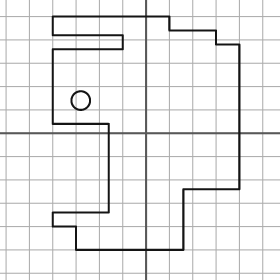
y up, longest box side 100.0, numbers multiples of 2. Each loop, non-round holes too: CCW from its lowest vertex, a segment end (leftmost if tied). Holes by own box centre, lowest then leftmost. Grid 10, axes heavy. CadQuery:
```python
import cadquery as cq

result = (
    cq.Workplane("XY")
    .moveTo(-30.0, -50.0)
    .lineTo(16.0, -50.0)
    .lineTo(16.0, -24.0)
    .lineTo(40.0, -24.0)
    .lineTo(40.0, 38.0)
    .lineTo(30.0, 38.0)
    .lineTo(30.0, 44.0)
    .lineTo(10.0, 44.0)
    .lineTo(10.0, 50.0)
    .lineTo(-40.0, 50.0)
    .lineTo(-40.0, 42.0)
    .lineTo(-10.0, 42.0)
    .lineTo(-10.0, 36.0)
    .lineTo(-40.0, 36.0)
    .lineTo(-40.0, 4.0)
    .lineTo(-16.0, 4.0)
    .lineTo(-16.0, -34.0)
    .lineTo(-40.0, -34.0)
    .lineTo(-40.0, -40.0)
    .lineTo(-30.0, -40.0)
    .close()
    .moveTo(-28.0, 14.0)
    .circle(4.0)
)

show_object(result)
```